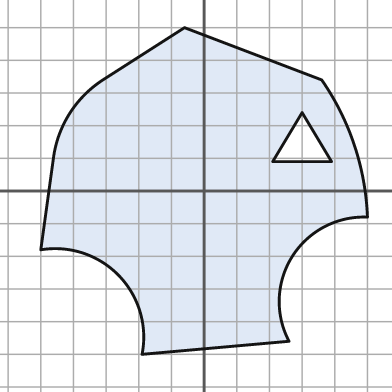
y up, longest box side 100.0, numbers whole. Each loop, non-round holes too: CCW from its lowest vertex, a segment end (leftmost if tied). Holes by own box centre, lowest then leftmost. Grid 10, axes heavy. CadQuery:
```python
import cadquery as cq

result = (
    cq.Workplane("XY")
    .moveTo(-19.0, -50.0)
    .lineTo(26.0, -46.0)
    .threePointArc((27.0, -20.0), (50.0, -8.0))
    .threePointArc((46.0, 14.0), (36.0, 34.0))
    .lineTo(-6.0, 50.0)
    .lineTo(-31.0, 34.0)
    .threePointArc((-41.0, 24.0), (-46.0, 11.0))
    .lineTo(-50.0, -18.0)
    .threePointArc((-26.0, -26.0), (-19.0, -50.0))
    .close()
    .moveTo(21.0, 9.0)
    .lineTo(39.0, 9.0)
    .lineTo(30.0, 24.0)
    .close()
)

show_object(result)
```